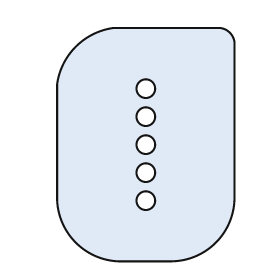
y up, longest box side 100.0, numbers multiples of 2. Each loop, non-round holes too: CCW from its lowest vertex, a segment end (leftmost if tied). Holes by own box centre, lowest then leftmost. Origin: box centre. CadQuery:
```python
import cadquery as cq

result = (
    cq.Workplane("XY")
    .moveTo(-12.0, -50.0)
    .lineTo(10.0, -50.0)
    .threePointArc((30.0, -42.0), (38.0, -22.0))
    .lineTo(38.0, 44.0)
    .threePointArc((36.0, 48.0), (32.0, 50.0))
    .lineTo(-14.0, 50.0)
    .threePointArc((-30.0, 42.0), (-38.0, 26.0))
    .lineTo(-38.0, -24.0)
    .threePointArc((-30.0, -42.0), (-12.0, -50.0))
    .close()
    .moveTo(0.0, -24.0)
    .circle(4.0)
    .moveTo(0.0, -12.0)
    .circle(4.0)
    .moveTo(0.0, 0.0)
    .circle(4.0)
    .moveTo(0.0, 12.0)
    .circle(4.0)
    .moveTo(0.0, 24.0)
    .circle(4.0)
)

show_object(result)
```